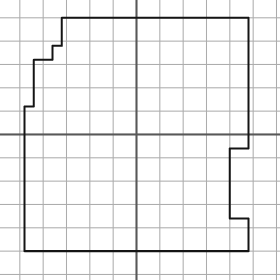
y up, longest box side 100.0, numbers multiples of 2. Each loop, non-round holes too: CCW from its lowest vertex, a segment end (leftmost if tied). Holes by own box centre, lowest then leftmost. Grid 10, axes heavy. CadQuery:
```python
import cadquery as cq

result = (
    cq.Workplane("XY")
    .moveTo(-48.0, -50.0)
    .lineTo(48.0, -50.0)
    .lineTo(48.0, -36.0)
    .lineTo(40.0, -36.0)
    .lineTo(40.0, -6.0)
    .lineTo(48.0, -6.0)
    .lineTo(48.0, 50.0)
    .lineTo(-32.0, 50.0)
    .lineTo(-32.0, 38.0)
    .lineTo(-36.0, 38.0)
    .lineTo(-36.0, 32.0)
    .lineTo(-44.0, 32.0)
    .lineTo(-44.0, 12.0)
    .lineTo(-48.0, 12.0)
    .close()
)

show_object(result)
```